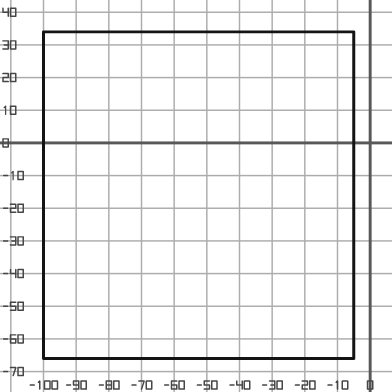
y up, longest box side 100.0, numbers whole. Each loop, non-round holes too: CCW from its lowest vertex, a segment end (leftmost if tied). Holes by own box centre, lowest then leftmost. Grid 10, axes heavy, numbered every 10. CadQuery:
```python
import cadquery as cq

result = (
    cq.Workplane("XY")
    .moveTo(-100.0, -66.0)
    .lineTo(-5.0, -66.0)
    .lineTo(-5.0, 34.0)
    .lineTo(-100.0, 34.0)
    .close()
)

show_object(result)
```